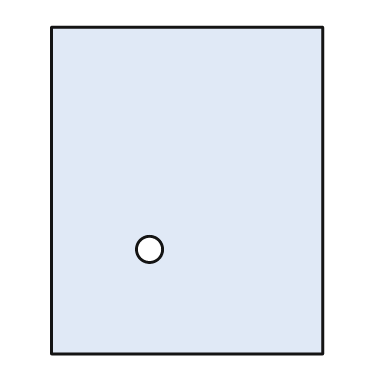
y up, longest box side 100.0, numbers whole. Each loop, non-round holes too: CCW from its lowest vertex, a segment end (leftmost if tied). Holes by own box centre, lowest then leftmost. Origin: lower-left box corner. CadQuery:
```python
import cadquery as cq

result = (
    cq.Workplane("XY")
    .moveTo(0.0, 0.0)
    .lineTo(83.0, 0.0)
    .lineTo(83.0, 100.0)
    .lineTo(0.0, 100.0)
    .close()
    .moveTo(30.0, 32.0)
    .circle(4.0)
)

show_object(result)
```